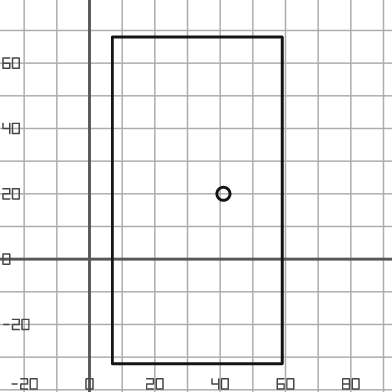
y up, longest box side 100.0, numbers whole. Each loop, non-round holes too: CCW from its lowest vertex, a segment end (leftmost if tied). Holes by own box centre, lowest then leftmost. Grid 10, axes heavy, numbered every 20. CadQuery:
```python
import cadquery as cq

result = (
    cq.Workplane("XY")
    .moveTo(7.0, -32.0)
    .lineTo(59.0, -32.0)
    .lineTo(59.0, 68.0)
    .lineTo(7.0, 68.0)
    .close()
    .moveTo(41.0, 20.0)
    .circle(2.0)
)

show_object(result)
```